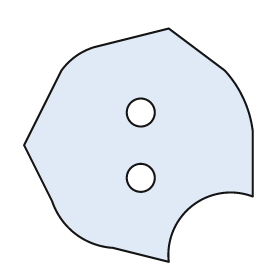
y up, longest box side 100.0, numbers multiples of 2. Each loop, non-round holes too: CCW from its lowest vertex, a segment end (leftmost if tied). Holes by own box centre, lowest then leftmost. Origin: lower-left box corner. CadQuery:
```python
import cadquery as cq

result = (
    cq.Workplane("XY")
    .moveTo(62.0, 0.0)
    .threePointArc((72.0, 24.0), (98.0, 28.0))
    .lineTo(98.0, 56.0)
    .threePointArc((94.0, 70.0), (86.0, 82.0))
    .lineTo(62.0, 100.0)
    .lineTo(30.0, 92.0)
    .threePointArc((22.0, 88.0), (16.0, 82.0))
    .lineTo(0.0, 50.0)
    .lineTo(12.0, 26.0)
    .threePointArc((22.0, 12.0), (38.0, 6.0))
    .close()
    .moveTo(50.0, 36.0)
    .circle(6.0)
    .moveTo(50.0, 64.0)
    .circle(6.0)
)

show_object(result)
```